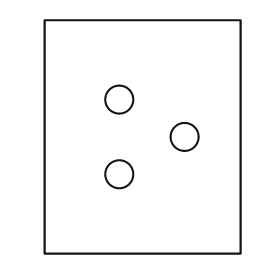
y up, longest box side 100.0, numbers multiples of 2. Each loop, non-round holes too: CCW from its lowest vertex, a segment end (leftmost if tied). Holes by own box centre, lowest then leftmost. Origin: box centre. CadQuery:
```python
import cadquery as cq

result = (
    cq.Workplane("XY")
    .moveTo(-42.0, -50.0)
    .lineTo(42.0, -50.0)
    .lineTo(42.0, 50.0)
    .lineTo(-42.0, 50.0)
    .close()
    .moveTo(-10.0, -16.0)
    .circle(6.0)
    .moveTo(18.0, 0.0)
    .circle(6.0)
    .moveTo(-10.0, 16.0)
    .circle(6.0)
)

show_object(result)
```